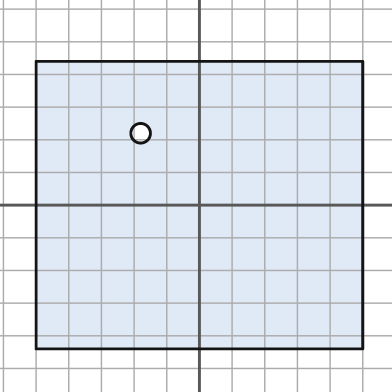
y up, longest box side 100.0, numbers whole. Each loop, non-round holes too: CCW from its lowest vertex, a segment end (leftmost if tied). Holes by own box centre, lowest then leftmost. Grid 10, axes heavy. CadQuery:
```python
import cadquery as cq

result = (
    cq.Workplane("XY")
    .moveTo(-50.0, -44.0)
    .lineTo(50.0, -44.0)
    .lineTo(50.0, 44.0)
    .lineTo(-50.0, 44.0)
    .close()
    .moveTo(-18.0, 22.0)
    .circle(3.0)
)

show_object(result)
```